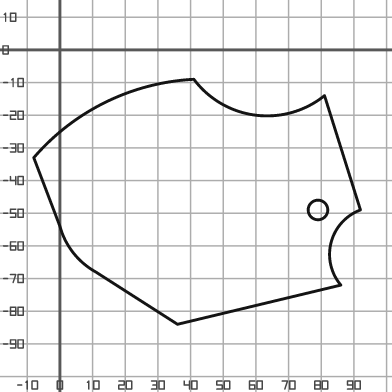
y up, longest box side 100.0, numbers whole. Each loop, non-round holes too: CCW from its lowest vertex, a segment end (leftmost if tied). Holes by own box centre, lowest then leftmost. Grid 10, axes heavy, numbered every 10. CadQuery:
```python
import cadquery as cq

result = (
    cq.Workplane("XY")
    .moveTo(36.0, -84.0)
    .lineTo(86.0, -72.0)
    .threePointArc((83.0, -59.0), (92.0, -49.0))
    .lineTo(81.0, -14.0)
    .threePointArc((60.0, -20.0), (41.0, -9.0))
    .threePointArc((14.0, -16.0), (-8.0, -33.0))
    .lineTo(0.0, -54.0)
    .threePointArc((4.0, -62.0), (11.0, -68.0))
    .close()
    .moveTo(79.0, -49.0)
    .circle(3.0)
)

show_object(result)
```